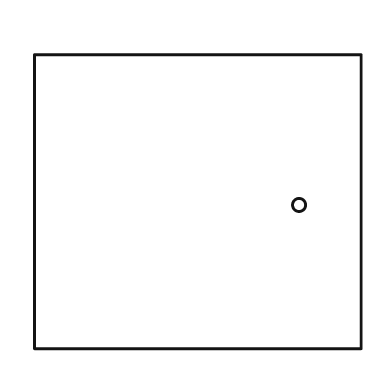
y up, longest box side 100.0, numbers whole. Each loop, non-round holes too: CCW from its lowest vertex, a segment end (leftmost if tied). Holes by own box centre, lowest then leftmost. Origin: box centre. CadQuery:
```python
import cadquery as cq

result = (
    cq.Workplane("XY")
    .moveTo(-50.0, -45.0)
    .lineTo(50.0, -45.0)
    .lineTo(50.0, 45.0)
    .lineTo(-50.0, 45.0)
    .close()
    .moveTo(31.0, -1.0)
    .circle(2.0)
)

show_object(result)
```